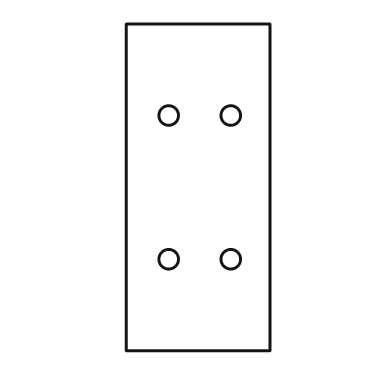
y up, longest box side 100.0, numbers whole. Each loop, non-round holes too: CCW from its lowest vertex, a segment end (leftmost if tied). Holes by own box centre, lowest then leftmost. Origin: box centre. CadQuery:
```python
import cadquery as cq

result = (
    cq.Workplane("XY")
    .moveTo(-22.0, -50.0)
    .lineTo(22.0, -50.0)
    .lineTo(22.0, 50.0)
    .lineTo(-22.0, 50.0)
    .close()
    .moveTo(-9.0, -22.0)
    .circle(3.0)
    .moveTo(10.0, -22.0)
    .circle(3.0)
    .moveTo(-9.0, 22.0)
    .circle(3.0)
    .moveTo(10.0, 22.0)
    .circle(3.0)
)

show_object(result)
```